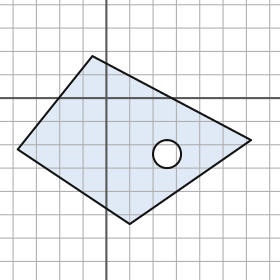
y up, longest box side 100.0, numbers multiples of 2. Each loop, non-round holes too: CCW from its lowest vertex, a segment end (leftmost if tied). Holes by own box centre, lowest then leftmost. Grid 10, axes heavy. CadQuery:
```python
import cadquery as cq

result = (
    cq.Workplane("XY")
    .moveTo(10.0, -54.0)
    .lineTo(62.0, -18.0)
    .lineTo(-6.0, 18.0)
    .lineTo(-38.0, -22.0)
    .close()
    .moveTo(26.0, -24.0)
    .circle(6.0)
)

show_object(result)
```